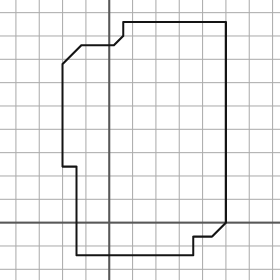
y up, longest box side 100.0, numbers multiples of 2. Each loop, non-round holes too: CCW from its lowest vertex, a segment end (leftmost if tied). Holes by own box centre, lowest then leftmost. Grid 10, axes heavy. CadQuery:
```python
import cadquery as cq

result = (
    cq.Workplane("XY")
    .moveTo(-14.0, -14.0)
    .lineTo(36.0, -14.0)
    .lineTo(36.0, -6.0)
    .lineTo(44.0, -6.0)
    .lineTo(50.0, 0.0)
    .lineTo(50.0, 86.0)
    .lineTo(6.0, 86.0)
    .lineTo(6.0, 80.0)
    .lineTo(2.0, 76.0)
    .lineTo(-12.0, 76.0)
    .lineTo(-20.0, 68.0)
    .lineTo(-20.0, 24.0)
    .lineTo(-14.0, 24.0)
    .close()
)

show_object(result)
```